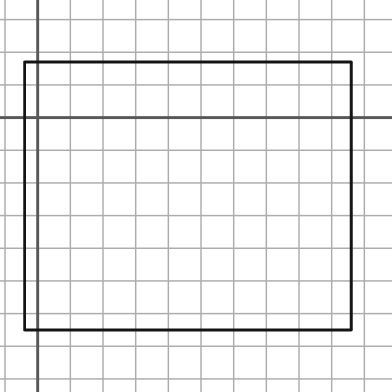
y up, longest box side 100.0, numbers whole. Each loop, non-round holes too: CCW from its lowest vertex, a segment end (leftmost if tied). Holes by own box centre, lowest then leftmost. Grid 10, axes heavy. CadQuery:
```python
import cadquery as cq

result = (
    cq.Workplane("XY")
    .moveTo(-4.0, -65.0)
    .lineTo(96.0, -65.0)
    .lineTo(96.0, 17.0)
    .lineTo(-4.0, 17.0)
    .close()
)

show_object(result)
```